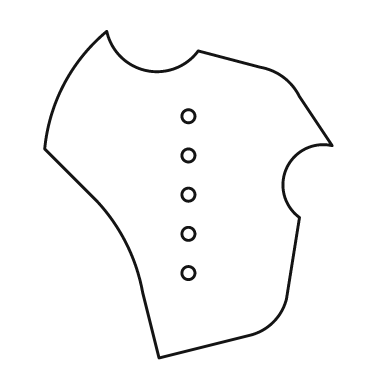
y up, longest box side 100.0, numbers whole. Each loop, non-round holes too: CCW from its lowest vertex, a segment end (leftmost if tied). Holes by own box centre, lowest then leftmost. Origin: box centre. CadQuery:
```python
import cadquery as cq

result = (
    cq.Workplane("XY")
    .moveTo(-9.0, -50.0)
    .lineTo(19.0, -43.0)
    .threePointArc((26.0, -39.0), (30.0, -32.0))
    .lineTo(34.0, -7.0)
    .threePointArc((30.0, 8.0), (44.0, 15.0))
    .lineTo(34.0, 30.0)
    .threePointArc((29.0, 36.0), (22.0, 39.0))
    .lineTo(3.0, 44.0)
    .threePointArc((-13.0, 38.0), (-25.0, 50.0))
    .threePointArc((-38.0, 34.0), (-44.0, 14.0))
    .lineTo(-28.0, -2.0)
    .threePointArc((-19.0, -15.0), (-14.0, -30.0))
    .close()
    .moveTo(0.0, -24.0)
    .circle(2.0)
    .moveTo(0.0, -12.0)
    .circle(2.0)
    .moveTo(0.0, 0.0)
    .circle(2.0)
    .moveTo(0.0, 12.0)
    .circle(2.0)
    .moveTo(0.0, 24.0)
    .circle(2.0)
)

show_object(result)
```